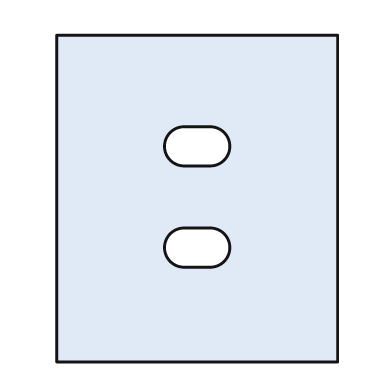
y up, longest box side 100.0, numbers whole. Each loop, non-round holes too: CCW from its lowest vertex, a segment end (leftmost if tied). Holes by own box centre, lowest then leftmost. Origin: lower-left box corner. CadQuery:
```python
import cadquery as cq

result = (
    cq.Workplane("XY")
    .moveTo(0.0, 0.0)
    .lineTo(86.0, 0.0)
    .lineTo(86.0, 100.0)
    .lineTo(0.0, 100.0)
    .close()
    .moveTo(39.0, 29.0)
    .lineTo(47.0, 29.0)
    .threePointArc((53.0, 35.0), (47.0, 41.0))
    .lineTo(39.0, 41.0)
    .threePointArc((33.0, 35.0), (39.0, 29.0))
    .close()
    .moveTo(39.0, 60.0)
    .lineTo(47.0, 60.0)
    .threePointArc((53.0, 66.0), (47.0, 72.0))
    .lineTo(39.0, 72.0)
    .threePointArc((33.0, 66.0), (39.0, 60.0))
    .close()
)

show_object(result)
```